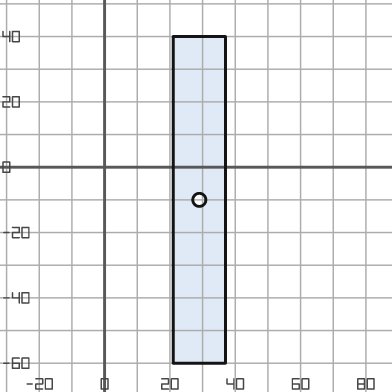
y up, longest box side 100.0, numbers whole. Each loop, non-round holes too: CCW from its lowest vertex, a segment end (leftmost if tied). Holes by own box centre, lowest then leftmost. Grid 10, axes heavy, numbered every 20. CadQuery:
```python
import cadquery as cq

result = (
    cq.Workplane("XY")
    .moveTo(21.0, -60.0)
    .lineTo(37.0, -60.0)
    .lineTo(37.0, 40.0)
    .lineTo(21.0, 40.0)
    .close()
    .moveTo(29.0, -10.0)
    .circle(2.0)
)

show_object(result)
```